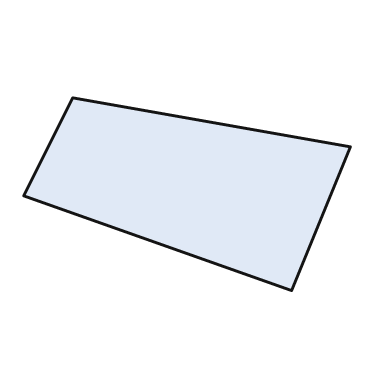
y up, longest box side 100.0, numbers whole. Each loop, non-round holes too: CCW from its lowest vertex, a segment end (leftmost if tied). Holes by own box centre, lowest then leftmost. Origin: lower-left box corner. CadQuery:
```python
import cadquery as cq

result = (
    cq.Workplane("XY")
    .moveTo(82.0, 0.0)
    .lineTo(100.0, 44.0)
    .lineTo(15.0, 59.0)
    .lineTo(0.0, 29.0)
    .close()
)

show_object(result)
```